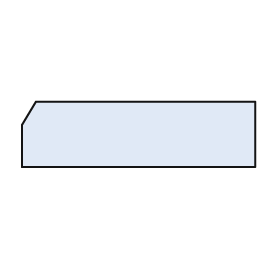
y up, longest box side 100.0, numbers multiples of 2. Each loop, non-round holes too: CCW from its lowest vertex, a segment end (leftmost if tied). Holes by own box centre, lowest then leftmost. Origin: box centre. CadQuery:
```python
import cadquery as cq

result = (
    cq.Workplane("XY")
    .moveTo(-50.0, -14.0)
    .lineTo(50.0, -14.0)
    .lineTo(50.0, 14.0)
    .lineTo(-44.0, 14.0)
    .lineTo(-50.0, 4.0)
    .close()
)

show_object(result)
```